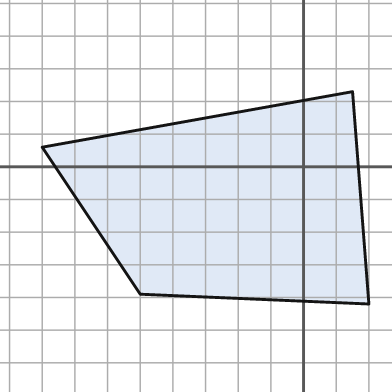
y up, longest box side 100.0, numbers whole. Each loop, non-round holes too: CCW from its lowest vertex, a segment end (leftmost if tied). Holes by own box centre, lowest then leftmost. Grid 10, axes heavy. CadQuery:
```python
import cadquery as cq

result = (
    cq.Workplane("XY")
    .moveTo(20.0, -42.0)
    .lineTo(15.0, 23.0)
    .lineTo(-80.0, 6.0)
    .lineTo(-50.0, -39.0)
    .close()
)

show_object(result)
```